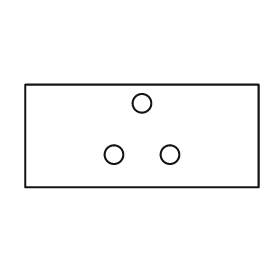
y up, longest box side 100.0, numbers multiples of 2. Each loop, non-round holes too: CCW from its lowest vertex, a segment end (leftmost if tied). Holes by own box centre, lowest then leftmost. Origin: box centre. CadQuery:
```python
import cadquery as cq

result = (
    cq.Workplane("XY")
    .moveTo(-50.0, -22.0)
    .lineTo(50.0, -22.0)
    .lineTo(50.0, 22.0)
    .lineTo(-50.0, 22.0)
    .close()
    .moveTo(-12.0, -8.0)
    .circle(4.0)
    .moveTo(12.0, -8.0)
    .circle(4.0)
    .moveTo(0.0, 14.0)
    .circle(4.0)
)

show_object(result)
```